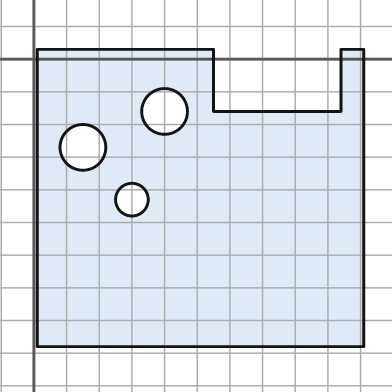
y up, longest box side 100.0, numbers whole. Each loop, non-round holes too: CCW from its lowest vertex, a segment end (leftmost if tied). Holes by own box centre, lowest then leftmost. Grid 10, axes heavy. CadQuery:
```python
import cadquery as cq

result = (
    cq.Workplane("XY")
    .moveTo(1.0, -88.0)
    .lineTo(101.0, -88.0)
    .lineTo(101.0, 3.0)
    .lineTo(94.0, 3.0)
    .lineTo(94.0, -16.0)
    .lineTo(55.0, -16.0)
    .lineTo(55.0, 3.0)
    .lineTo(1.0, 3.0)
    .close()
    .moveTo(30.0, -43.0)
    .circle(5.0)
    .moveTo(15.0, -27.0)
    .circle(7.0)
    .moveTo(40.0, -16.0)
    .circle(7.0)
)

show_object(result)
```